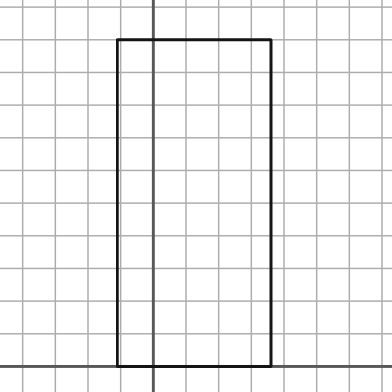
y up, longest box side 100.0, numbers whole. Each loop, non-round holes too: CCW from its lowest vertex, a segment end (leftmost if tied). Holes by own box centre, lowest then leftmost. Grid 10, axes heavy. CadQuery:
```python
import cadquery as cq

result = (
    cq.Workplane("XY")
    .moveTo(-11.0, 0.0)
    .lineTo(36.0, 0.0)
    .lineTo(36.0, 100.0)
    .lineTo(-11.0, 100.0)
    .close()
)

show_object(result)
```